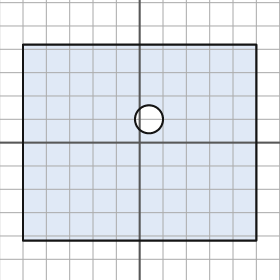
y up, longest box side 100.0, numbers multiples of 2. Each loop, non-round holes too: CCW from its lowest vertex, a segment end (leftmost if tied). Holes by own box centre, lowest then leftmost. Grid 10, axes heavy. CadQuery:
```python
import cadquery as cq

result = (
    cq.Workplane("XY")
    .moveTo(-50.0, -42.0)
    .lineTo(50.0, -42.0)
    .lineTo(50.0, 42.0)
    .lineTo(-50.0, 42.0)
    .close()
    .moveTo(4.0, 10.0)
    .circle(6.0)
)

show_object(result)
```